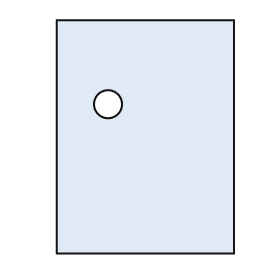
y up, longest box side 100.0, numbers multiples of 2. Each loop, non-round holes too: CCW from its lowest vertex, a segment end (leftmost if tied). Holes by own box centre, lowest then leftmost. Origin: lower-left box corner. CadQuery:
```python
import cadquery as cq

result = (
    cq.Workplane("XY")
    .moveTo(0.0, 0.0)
    .lineTo(76.0, 0.0)
    .lineTo(76.0, 100.0)
    .lineTo(0.0, 100.0)
    .close()
    .moveTo(22.0, 64.0)
    .circle(6.0)
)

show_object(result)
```